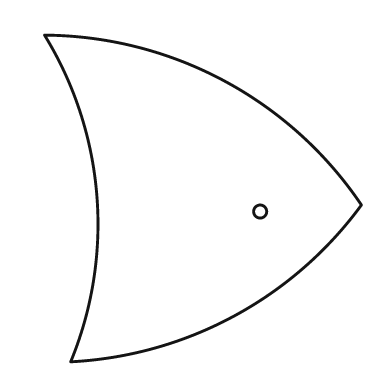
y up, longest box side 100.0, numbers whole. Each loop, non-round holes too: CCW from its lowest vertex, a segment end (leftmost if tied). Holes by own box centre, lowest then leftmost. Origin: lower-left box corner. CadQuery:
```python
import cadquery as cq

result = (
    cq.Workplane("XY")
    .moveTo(8.0, 0.0)
    .threePointArc((58.0, 14.0), (97.0, 48.0))
    .threePointArc((55.0, 86.0), (0.0, 100.0))
    .threePointArc((16.0, 51.0), (8.0, 0.0))
    .close()
    .moveTo(66.0, 46.0)
    .circle(2.0)
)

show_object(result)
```